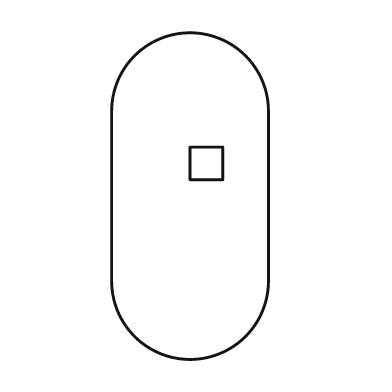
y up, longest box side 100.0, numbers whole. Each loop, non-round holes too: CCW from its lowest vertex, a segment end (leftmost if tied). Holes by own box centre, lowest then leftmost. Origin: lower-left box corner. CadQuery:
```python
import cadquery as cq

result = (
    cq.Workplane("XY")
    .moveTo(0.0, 24.0)
    .threePointArc((24.0, 0.0), (48.0, 24.0))
    .lineTo(48.0, 76.0)
    .threePointArc((24.0, 100.0), (0.0, 76.0))
    .close()
    .moveTo(24.0, 55.0)
    .lineTo(34.0, 55.0)
    .lineTo(34.0, 65.0)
    .lineTo(24.0, 65.0)
    .close()
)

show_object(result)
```